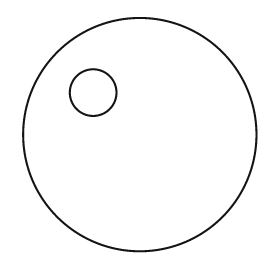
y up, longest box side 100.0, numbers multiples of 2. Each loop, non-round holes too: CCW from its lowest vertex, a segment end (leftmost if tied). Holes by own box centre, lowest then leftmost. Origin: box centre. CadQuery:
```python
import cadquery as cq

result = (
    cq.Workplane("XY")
    .moveTo(0.0, 0.0)
    .circle(50.0)
    .moveTo(-20.0, 18.0)
    .circle(10.0)
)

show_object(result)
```